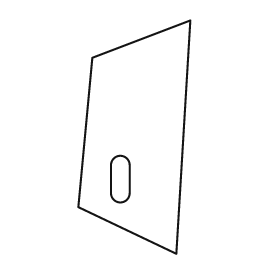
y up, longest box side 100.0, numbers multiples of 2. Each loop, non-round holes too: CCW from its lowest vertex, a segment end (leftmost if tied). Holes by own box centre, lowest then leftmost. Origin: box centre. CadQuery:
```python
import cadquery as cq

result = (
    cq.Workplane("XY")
    .moveTo(18.0, -50.0)
    .lineTo(24.0, 50.0)
    .lineTo(-18.0, 34.0)
    .lineTo(-24.0, -30.0)
    .close()
    .moveTo(-10.0, -24.0)
    .threePointArc((-6.0, -28.0), (-2.0, -24.0))
    .lineTo(-2.0, -12.0)
    .threePointArc((-6.0, -8.0), (-10.0, -12.0))
    .close()
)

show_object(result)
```